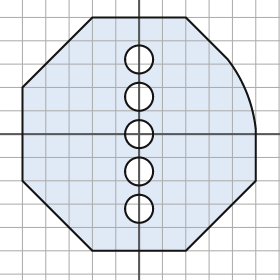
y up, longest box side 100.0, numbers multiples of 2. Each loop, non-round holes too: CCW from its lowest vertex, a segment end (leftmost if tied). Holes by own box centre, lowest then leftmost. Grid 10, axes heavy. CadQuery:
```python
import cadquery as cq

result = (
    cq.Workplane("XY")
    .moveTo(-20.0, -50.0)
    .lineTo(20.0, -50.0)
    .lineTo(50.0, -20.0)
    .lineTo(50.0, 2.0)
    .threePointArc((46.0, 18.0), (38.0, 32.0))
    .lineTo(20.0, 50.0)
    .lineTo(-20.0, 50.0)
    .lineTo(-50.0, 20.0)
    .lineTo(-50.0, -20.0)
    .close()
    .moveTo(0.0, -32.0)
    .circle(6.0)
    .moveTo(0.0, -16.0)
    .circle(6.0)
    .moveTo(0.0, 0.0)
    .circle(6.0)
    .moveTo(0.0, 16.0)
    .circle(6.0)
    .moveTo(0.0, 32.0)
    .circle(6.0)
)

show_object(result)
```